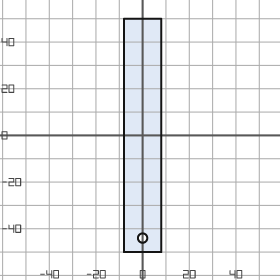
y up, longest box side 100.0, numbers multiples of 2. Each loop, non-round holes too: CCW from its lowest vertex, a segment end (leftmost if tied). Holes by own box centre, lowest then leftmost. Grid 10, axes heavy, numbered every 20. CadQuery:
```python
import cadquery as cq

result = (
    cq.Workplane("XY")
    .moveTo(-8.0, -50.0)
    .lineTo(8.0, -50.0)
    .lineTo(8.0, 50.0)
    .lineTo(-8.0, 50.0)
    .close()
    .moveTo(0.0, -44.0)
    .circle(2.0)
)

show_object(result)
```